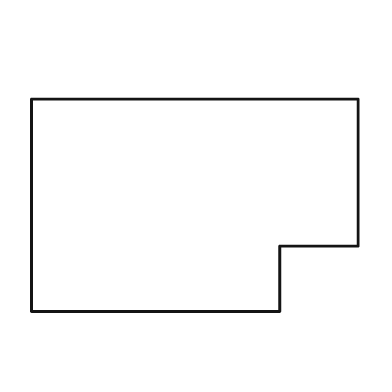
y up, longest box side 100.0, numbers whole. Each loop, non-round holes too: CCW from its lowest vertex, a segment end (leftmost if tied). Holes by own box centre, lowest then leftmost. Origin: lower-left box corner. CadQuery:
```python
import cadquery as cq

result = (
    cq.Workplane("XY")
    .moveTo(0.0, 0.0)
    .lineTo(76.0, 0.0)
    .lineTo(76.0, 20.0)
    .lineTo(100.0, 20.0)
    .lineTo(100.0, 65.0)
    .lineTo(0.0, 65.0)
    .close()
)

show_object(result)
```